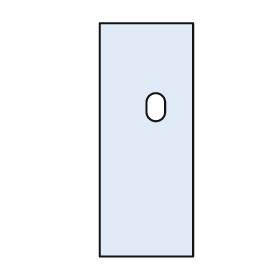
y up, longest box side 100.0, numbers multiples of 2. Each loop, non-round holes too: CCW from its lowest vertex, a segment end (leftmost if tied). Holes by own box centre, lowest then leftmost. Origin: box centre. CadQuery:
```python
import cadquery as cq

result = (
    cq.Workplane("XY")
    .moveTo(-20.0, -50.0)
    .lineTo(20.0, -50.0)
    .lineTo(20.0, 50.0)
    .lineTo(-20.0, 50.0)
    .close()
    .moveTo(0.0, 12.0)
    .threePointArc((4.0, 8.0), (8.0, 12.0))
    .lineTo(8.0, 16.0)
    .threePointArc((4.0, 20.0), (0.0, 16.0))
    .close()
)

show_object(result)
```